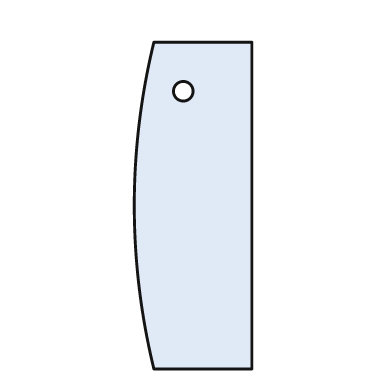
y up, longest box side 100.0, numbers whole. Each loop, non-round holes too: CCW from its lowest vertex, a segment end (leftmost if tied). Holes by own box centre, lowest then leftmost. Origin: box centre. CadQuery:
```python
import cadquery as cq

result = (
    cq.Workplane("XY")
    .moveTo(-12.0, -50.0)
    .lineTo(18.0, -50.0)
    .lineTo(18.0, 50.0)
    .lineTo(-12.0, 50.0)
    .threePointArc((-18.0, 0.0), (-12.0, -50.0))
    .close()
    .moveTo(-3.0, 35.0)
    .circle(3.0)
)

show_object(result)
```